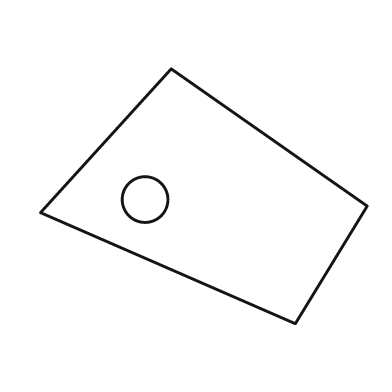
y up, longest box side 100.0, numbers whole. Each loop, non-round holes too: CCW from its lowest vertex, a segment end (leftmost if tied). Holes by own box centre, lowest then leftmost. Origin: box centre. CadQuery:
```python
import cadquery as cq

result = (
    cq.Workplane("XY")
    .moveTo(28.0, -39.0)
    .lineTo(50.0, -3.0)
    .lineTo(-10.0, 39.0)
    .lineTo(-50.0, -5.0)
    .close()
    .moveTo(-18.0, -1.0)
    .circle(7.0)
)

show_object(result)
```